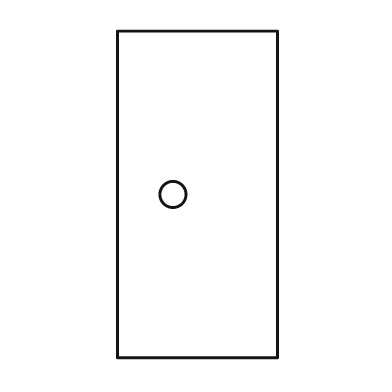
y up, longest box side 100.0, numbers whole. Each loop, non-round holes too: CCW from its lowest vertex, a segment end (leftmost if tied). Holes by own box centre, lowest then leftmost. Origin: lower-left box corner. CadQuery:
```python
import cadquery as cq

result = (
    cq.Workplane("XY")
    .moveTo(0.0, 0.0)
    .lineTo(49.0, 0.0)
    .lineTo(49.0, 100.0)
    .lineTo(0.0, 100.0)
    .close()
    .moveTo(17.0, 50.0)
    .circle(4.0)
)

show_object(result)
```